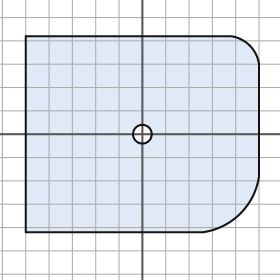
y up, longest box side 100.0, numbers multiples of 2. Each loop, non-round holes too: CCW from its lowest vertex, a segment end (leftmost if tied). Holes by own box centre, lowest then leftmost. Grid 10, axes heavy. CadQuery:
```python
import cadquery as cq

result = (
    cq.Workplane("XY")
    .moveTo(-50.0, -42.0)
    .lineTo(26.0, -42.0)
    .threePointArc((42.0, -34.0), (50.0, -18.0))
    .lineTo(50.0, 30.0)
    .threePointArc((46.0, 38.0), (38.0, 42.0))
    .lineTo(-50.0, 42.0)
    .close()
    .moveTo(0.0, 0.0)
    .circle(4.0)
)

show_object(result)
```